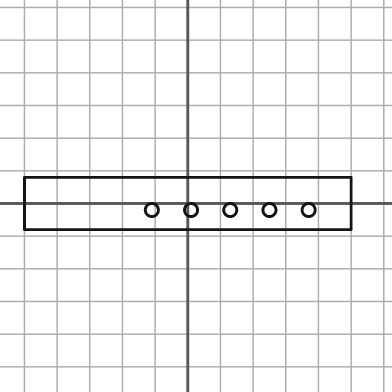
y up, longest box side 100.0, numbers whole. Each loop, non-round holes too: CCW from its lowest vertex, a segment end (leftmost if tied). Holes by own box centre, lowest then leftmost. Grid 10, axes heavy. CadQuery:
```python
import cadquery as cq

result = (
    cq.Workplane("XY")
    .moveTo(-50.0, -8.0)
    .lineTo(50.0, -8.0)
    .lineTo(50.0, 8.0)
    .lineTo(-50.0, 8.0)
    .close()
    .moveTo(-11.0, -2.0)
    .circle(2.0)
    .moveTo(1.0, -2.0)
    .circle(2.0)
    .moveTo(13.0, -2.0)
    .circle(2.0)
    .moveTo(25.0, -2.0)
    .circle(2.0)
    .moveTo(37.0, -2.0)
    .circle(2.0)
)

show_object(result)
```